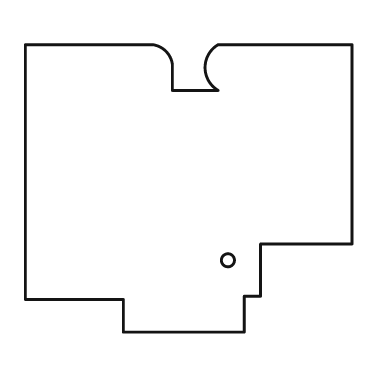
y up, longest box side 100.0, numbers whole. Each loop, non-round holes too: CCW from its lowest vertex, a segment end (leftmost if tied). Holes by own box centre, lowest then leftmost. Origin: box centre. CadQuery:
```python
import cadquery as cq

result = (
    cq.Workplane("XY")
    .moveTo(-20.0, -44.0)
    .lineTo(17.0, -44.0)
    .lineTo(17.0, -33.0)
    .lineTo(22.0, -33.0)
    .lineTo(22.0, -17.0)
    .lineTo(50.0, -17.0)
    .lineTo(50.0, 44.0)
    .lineTo(9.0, 44.0)
    .threePointArc((5.0, 37.0), (9.0, 30.0))
    .lineTo(-5.0, 30.0)
    .lineTo(-5.0, 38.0)
    .threePointArc((-7.0, 42.0), (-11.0, 44.0))
    .lineTo(-50.0, 44.0)
    .lineTo(-50.0, -34.0)
    .lineTo(-20.0, -34.0)
    .close()
    .moveTo(12.0, -22.0)
    .circle(2.0)
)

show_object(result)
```